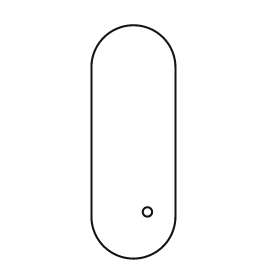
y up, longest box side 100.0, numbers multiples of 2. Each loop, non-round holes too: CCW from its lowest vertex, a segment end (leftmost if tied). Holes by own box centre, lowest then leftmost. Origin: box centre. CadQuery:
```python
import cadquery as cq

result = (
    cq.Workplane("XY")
    .moveTo(-18.0, -32.0)
    .threePointArc((0.0, -50.0), (18.0, -32.0))
    .lineTo(18.0, 32.0)
    .threePointArc((0.0, 50.0), (-18.0, 32.0))
    .close()
    .moveTo(6.0, -30.0)
    .circle(2.0)
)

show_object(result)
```